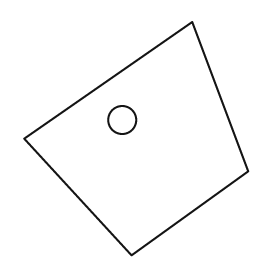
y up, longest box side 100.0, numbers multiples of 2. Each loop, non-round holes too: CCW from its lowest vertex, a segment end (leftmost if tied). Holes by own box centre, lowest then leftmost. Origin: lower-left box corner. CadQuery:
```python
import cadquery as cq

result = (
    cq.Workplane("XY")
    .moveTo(46.0, 0.0)
    .lineTo(96.0, 36.0)
    .lineTo(72.0, 100.0)
    .lineTo(0.0, 50.0)
    .close()
    .moveTo(42.0, 58.0)
    .circle(6.0)
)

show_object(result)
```